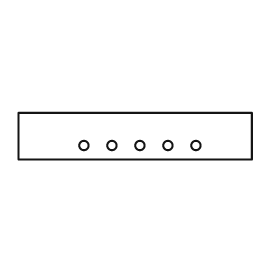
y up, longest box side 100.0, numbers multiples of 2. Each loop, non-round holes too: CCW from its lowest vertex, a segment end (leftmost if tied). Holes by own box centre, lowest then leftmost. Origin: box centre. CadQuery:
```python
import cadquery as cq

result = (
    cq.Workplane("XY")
    .moveTo(-50.0, -10.0)
    .lineTo(50.0, -10.0)
    .lineTo(50.0, 10.0)
    .lineTo(-50.0, 10.0)
    .close()
    .moveTo(-22.0, -4.0)
    .circle(2.0)
    .moveTo(-10.0, -4.0)
    .circle(2.0)
    .moveTo(2.0, -4.0)
    .circle(2.0)
    .moveTo(14.0, -4.0)
    .circle(2.0)
    .moveTo(26.0, -4.0)
    .circle(2.0)
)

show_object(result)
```